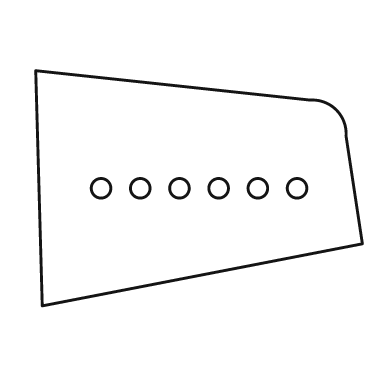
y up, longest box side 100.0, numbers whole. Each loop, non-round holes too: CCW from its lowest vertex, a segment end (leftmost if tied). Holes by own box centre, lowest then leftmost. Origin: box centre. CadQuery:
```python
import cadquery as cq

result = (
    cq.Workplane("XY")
    .moveTo(-48.0, -36.0)
    .lineTo(50.0, -17.0)
    .lineTo(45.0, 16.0)
    .threePointArc((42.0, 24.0), (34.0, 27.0))
    .lineTo(-50.0, 36.0)
    .close()
    .moveTo(-30.0, 0.0)
    .circle(3.0)
    .moveTo(-18.0, 0.0)
    .circle(3.0)
    .moveTo(-6.0, 0.0)
    .circle(3.0)
    .moveTo(6.0, 0.0)
    .circle(3.0)
    .moveTo(18.0, 0.0)
    .circle(3.0)
    .moveTo(30.0, 0.0)
    .circle(3.0)
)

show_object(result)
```